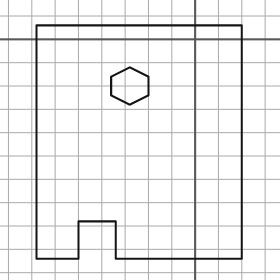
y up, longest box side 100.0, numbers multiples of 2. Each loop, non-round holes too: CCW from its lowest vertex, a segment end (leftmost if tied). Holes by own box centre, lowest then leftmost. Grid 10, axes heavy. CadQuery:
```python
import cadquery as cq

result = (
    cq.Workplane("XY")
    .moveTo(-68.0, -94.0)
    .lineTo(-50.0, -94.0)
    .lineTo(-50.0, -78.0)
    .lineTo(-34.0, -78.0)
    .lineTo(-34.0, -94.0)
    .lineTo(20.0, -94.0)
    .lineTo(20.0, 6.0)
    .lineTo(-68.0, 6.0)
    .close()
    .moveTo(-28.0, -28.0)
    .lineTo(-20.0, -24.0)
    .lineTo(-20.0, -16.0)
    .lineTo(-28.0, -12.0)
    .lineTo(-36.0, -16.0)
    .lineTo(-36.0, -24.0)
    .close()
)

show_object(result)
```